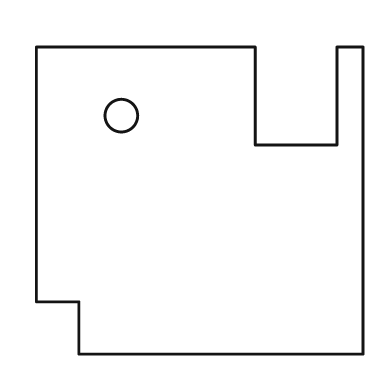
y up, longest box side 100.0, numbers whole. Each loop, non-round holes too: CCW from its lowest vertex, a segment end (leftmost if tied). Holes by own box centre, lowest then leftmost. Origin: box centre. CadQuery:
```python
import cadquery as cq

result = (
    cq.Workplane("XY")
    .moveTo(-37.0, -47.0)
    .lineTo(50.0, -47.0)
    .lineTo(50.0, 47.0)
    .lineTo(42.0, 47.0)
    .lineTo(42.0, 17.0)
    .lineTo(17.0, 17.0)
    .lineTo(17.0, 47.0)
    .lineTo(-50.0, 47.0)
    .lineTo(-50.0, -31.0)
    .lineTo(-37.0, -31.0)
    .close()
    .moveTo(-24.0, 26.0)
    .circle(5.0)
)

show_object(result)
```